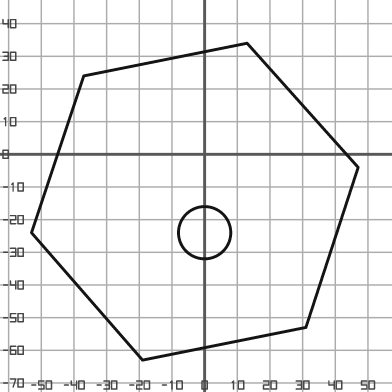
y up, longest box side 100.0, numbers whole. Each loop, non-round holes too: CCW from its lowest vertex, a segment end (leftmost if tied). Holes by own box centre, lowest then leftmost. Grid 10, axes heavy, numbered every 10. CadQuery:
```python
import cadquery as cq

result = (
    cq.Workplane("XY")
    .moveTo(-19.0, -63.0)
    .lineTo(31.0, -53.0)
    .lineTo(47.0, -4.0)
    .lineTo(13.0, 34.0)
    .lineTo(-37.0, 24.0)
    .lineTo(-53.0, -24.0)
    .close()
    .moveTo(0.0, -24.0)
    .circle(8.0)
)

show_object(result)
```